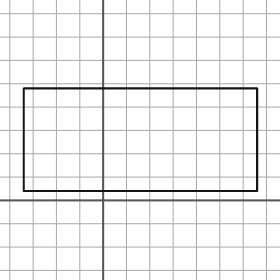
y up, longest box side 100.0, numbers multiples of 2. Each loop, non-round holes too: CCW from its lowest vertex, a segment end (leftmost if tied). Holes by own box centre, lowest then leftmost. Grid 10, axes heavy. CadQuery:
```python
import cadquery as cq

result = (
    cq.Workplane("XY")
    .moveTo(-34.0, 4.0)
    .lineTo(66.0, 4.0)
    .lineTo(66.0, 48.0)
    .lineTo(-34.0, 48.0)
    .close()
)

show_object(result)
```